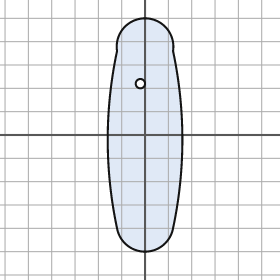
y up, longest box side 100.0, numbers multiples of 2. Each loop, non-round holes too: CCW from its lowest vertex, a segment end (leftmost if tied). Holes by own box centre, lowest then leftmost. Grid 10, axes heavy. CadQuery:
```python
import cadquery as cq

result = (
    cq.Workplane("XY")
    .moveTo(-12.0, -40.0)
    .threePointArc((0.0, -50.0), (12.0, -40.0))
    .threePointArc((16.0, -2.0), (12.0, 36.0))
    .threePointArc((0.0, 50.0), (-12.0, 36.0))
    .threePointArc((-16.0, -2.0), (-12.0, -40.0))
    .close()
    .moveTo(-2.0, 22.0)
    .circle(2.0)
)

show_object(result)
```